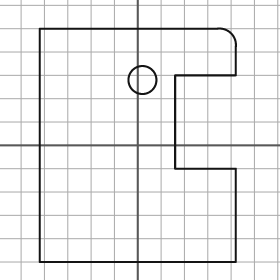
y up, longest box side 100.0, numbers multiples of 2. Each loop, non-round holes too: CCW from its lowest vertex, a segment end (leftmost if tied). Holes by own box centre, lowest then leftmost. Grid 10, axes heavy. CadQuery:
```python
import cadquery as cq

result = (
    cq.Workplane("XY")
    .moveTo(-42.0, -50.0)
    .lineTo(42.0, -50.0)
    .lineTo(42.0, -10.0)
    .lineTo(16.0, -10.0)
    .lineTo(16.0, 30.0)
    .lineTo(42.0, 30.0)
    .lineTo(42.0, 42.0)
    .threePointArc((40.0, 48.0), (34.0, 50.0))
    .lineTo(-42.0, 50.0)
    .close()
    .moveTo(2.0, 28.0)
    .circle(6.0)
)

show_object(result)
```